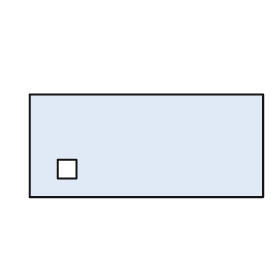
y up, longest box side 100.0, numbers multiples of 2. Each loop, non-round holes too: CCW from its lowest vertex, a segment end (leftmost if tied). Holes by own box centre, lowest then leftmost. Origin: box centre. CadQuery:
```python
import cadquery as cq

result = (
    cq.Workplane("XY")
    .moveTo(-50.0, -22.0)
    .lineTo(50.0, -22.0)
    .lineTo(50.0, 22.0)
    .lineTo(-50.0, 22.0)
    .close()
    .moveTo(-38.0, -14.0)
    .lineTo(-30.0, -14.0)
    .lineTo(-30.0, -6.0)
    .lineTo(-38.0, -6.0)
    .close()
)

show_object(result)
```